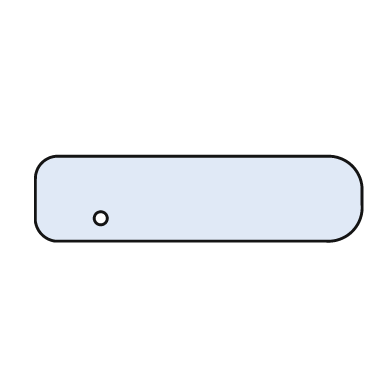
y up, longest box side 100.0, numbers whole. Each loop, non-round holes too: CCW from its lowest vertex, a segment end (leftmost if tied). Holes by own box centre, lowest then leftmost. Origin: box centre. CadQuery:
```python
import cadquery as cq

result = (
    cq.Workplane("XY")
    .moveTo(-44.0, -13.0)
    .lineTo(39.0, -13.0)
    .threePointArc((47.0, -10.0), (50.0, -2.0))
    .lineTo(50.0, 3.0)
    .threePointArc((47.0, 10.0), (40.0, 13.0))
    .lineTo(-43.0, 13.0)
    .threePointArc((-48.0, 11.0), (-50.0, 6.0))
    .lineTo(-50.0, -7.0)
    .threePointArc((-48.0, -11.0), (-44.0, -13.0))
    .close()
    .moveTo(-30.0, -6.0)
    .circle(2.0)
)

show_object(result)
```